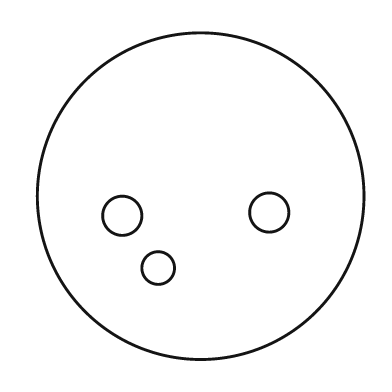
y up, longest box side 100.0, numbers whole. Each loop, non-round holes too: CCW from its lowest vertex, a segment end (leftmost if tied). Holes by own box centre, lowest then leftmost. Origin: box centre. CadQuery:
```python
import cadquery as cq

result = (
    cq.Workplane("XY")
    .moveTo(0.0, 0.0)
    .circle(50.0)
    .moveTo(-13.0, -22.0)
    .circle(5.0)
    .moveTo(-24.0, -6.0)
    .circle(6.0)
    .moveTo(21.0, -5.0)
    .circle(6.0)
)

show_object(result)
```